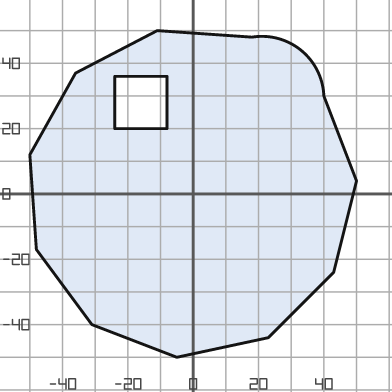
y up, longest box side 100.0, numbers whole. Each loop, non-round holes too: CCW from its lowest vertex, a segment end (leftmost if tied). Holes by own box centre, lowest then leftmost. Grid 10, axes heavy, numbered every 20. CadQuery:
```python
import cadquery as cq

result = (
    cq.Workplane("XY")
    .moveTo(-5.0, -50.0)
    .lineTo(23.0, -44.0)
    .lineTo(43.0, -24.0)
    .lineTo(50.0, 4.0)
    .lineTo(40.0, 30.0)
    .threePointArc((33.0, 44.0), (18.0, 48.0))
    .lineTo(-11.0, 50.0)
    .lineTo(-36.0, 37.0)
    .lineTo(-50.0, 12.0)
    .lineTo(-48.0, -17.0)
    .lineTo(-31.0, -40.0)
    .close()
    .moveTo(-24.0, 20.0)
    .lineTo(-8.0, 20.0)
    .lineTo(-8.0, 36.0)
    .lineTo(-24.0, 36.0)
    .close()
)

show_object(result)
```